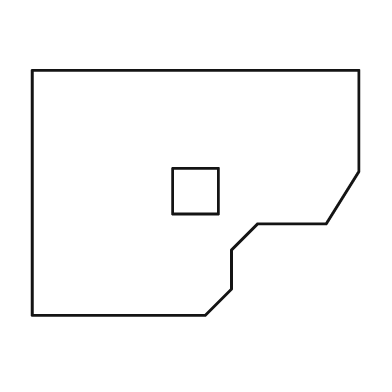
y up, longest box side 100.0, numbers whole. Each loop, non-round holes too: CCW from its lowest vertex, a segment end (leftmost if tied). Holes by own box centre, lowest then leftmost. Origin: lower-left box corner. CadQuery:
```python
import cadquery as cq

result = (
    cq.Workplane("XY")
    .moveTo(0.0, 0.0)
    .lineTo(53.0, 0.0)
    .lineTo(61.0, 8.0)
    .lineTo(61.0, 20.0)
    .lineTo(69.0, 28.0)
    .lineTo(90.0, 28.0)
    .lineTo(100.0, 44.0)
    .lineTo(100.0, 75.0)
    .lineTo(0.0, 75.0)
    .close()
    .moveTo(43.0, 31.0)
    .lineTo(57.0, 31.0)
    .lineTo(57.0, 45.0)
    .lineTo(43.0, 45.0)
    .close()
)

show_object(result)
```